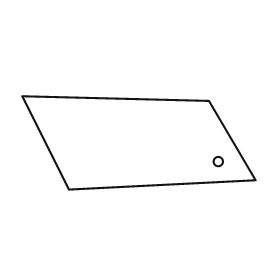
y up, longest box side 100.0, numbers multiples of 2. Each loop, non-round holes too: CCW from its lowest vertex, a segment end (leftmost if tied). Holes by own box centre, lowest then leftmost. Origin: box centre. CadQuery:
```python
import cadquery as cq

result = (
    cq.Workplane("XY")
    .moveTo(-30.0, -20.0)
    .lineTo(50.0, -16.0)
    .lineTo(30.0, 18.0)
    .lineTo(-50.0, 20.0)
    .close()
    .moveTo(34.0, -8.0)
    .circle(2.0)
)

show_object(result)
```